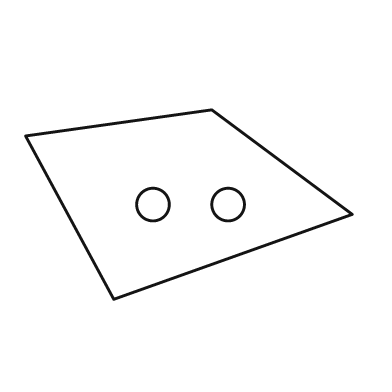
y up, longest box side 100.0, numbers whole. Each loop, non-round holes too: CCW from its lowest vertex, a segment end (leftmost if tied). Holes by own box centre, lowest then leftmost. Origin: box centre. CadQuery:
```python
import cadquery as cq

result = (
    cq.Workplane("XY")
    .moveTo(-23.0, -29.0)
    .lineTo(50.0, -3.0)
    .lineTo(7.0, 29.0)
    .lineTo(-50.0, 21.0)
    .close()
    .moveTo(-11.0, 0.0)
    .circle(5.0)
    .moveTo(12.0, 0.0)
    .circle(5.0)
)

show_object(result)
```